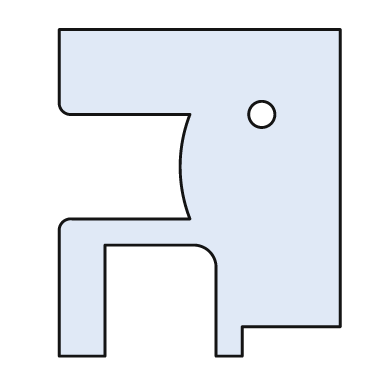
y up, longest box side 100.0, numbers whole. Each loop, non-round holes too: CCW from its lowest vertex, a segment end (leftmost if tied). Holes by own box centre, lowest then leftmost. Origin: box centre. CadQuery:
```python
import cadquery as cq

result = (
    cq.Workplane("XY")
    .moveTo(-43.0, -50.0)
    .lineTo(-29.0, -50.0)
    .lineTo(-29.0, -16.0)
    .lineTo(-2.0, -16.0)
    .threePointArc((3.0, -18.0), (5.0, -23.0))
    .lineTo(5.0, -50.0)
    .lineTo(13.0, -50.0)
    .lineTo(13.0, -41.0)
    .lineTo(43.0, -41.0)
    .lineTo(43.0, 50.0)
    .lineTo(-43.0, 50.0)
    .lineTo(-43.0, 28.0)
    .threePointArc((-42.0, 25.0), (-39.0, 24.0))
    .lineTo(-3.0, 24.0)
    .threePointArc((-6.0, 8.0), (-3.0, -8.0))
    .lineTo(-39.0, -8.0)
    .threePointArc((-42.0, -9.0), (-43.0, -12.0))
    .close()
    .moveTo(19.0, 24.0)
    .circle(4.0)
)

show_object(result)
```